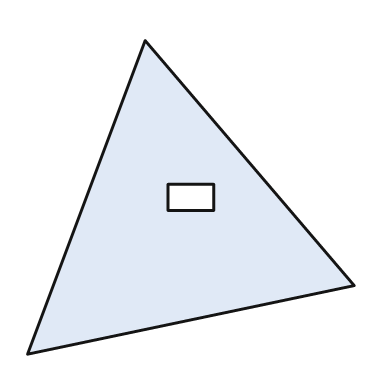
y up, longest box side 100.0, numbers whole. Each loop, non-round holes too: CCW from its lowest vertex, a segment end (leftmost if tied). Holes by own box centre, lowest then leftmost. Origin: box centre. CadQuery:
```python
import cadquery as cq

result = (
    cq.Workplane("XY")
    .moveTo(-50.0, -48.0)
    .lineTo(50.0, -27.0)
    .lineTo(-14.0, 48.0)
    .close()
    .moveTo(-7.0, -4.0)
    .lineTo(7.0, -4.0)
    .lineTo(7.0, 4.0)
    .lineTo(-7.0, 4.0)
    .close()
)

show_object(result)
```